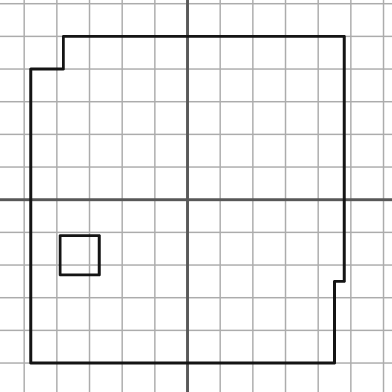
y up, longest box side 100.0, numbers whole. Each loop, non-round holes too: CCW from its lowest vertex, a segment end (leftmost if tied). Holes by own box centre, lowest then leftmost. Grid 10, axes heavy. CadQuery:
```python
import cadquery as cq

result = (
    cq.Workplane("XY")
    .moveTo(-48.0, -50.0)
    .lineTo(45.0, -50.0)
    .lineTo(45.0, -25.0)
    .lineTo(48.0, -25.0)
    .lineTo(48.0, 50.0)
    .lineTo(-38.0, 50.0)
    .lineTo(-38.0, 40.0)
    .lineTo(-48.0, 40.0)
    .close()
    .moveTo(-39.0, -23.0)
    .lineTo(-27.0, -23.0)
    .lineTo(-27.0, -11.0)
    .lineTo(-39.0, -11.0)
    .close()
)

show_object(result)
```